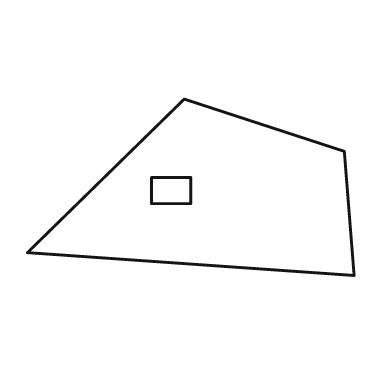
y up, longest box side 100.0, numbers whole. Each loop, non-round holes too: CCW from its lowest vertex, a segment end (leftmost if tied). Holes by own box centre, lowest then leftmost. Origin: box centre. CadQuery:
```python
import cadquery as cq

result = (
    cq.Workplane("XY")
    .moveTo(50.0, -27.0)
    .lineTo(47.0, 11.0)
    .lineTo(-2.0, 27.0)
    .lineTo(-50.0, -20.0)
    .close()
    .moveTo(-12.0, -5.0)
    .lineTo(0.0, -5.0)
    .lineTo(0.0, 3.0)
    .lineTo(-12.0, 3.0)
    .close()
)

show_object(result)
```